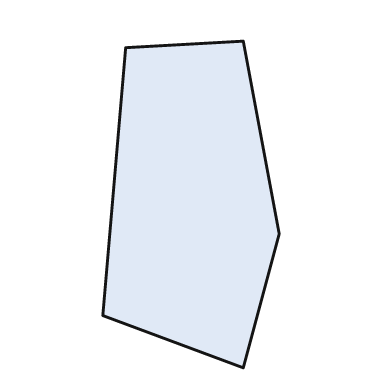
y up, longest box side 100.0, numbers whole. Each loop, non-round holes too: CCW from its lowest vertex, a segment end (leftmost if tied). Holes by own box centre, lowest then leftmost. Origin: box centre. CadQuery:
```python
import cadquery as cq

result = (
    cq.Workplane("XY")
    .moveTo(16.0, -50.0)
    .lineTo(27.0, -9.0)
    .lineTo(16.0, 50.0)
    .lineTo(-20.0, 48.0)
    .lineTo(-27.0, -34.0)
    .close()
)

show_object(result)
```